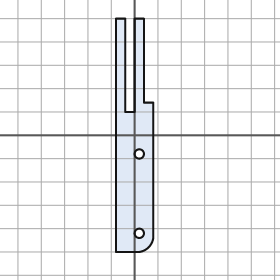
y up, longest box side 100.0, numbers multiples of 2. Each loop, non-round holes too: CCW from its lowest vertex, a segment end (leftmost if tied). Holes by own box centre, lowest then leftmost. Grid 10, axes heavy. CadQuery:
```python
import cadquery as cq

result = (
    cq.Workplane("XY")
    .moveTo(-8.0, -50.0)
    .lineTo(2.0, -50.0)
    .threePointArc((6.0, -48.0), (8.0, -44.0))
    .lineTo(8.0, 14.0)
    .lineTo(4.0, 14.0)
    .lineTo(4.0, 50.0)
    .lineTo(0.0, 50.0)
    .lineTo(0.0, 10.0)
    .lineTo(-4.0, 10.0)
    .lineTo(-4.0, 50.0)
    .lineTo(-8.0, 50.0)
    .close()
    .moveTo(2.0, -42.0)
    .circle(2.0)
    .moveTo(2.0, -8.0)
    .circle(2.0)
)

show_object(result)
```